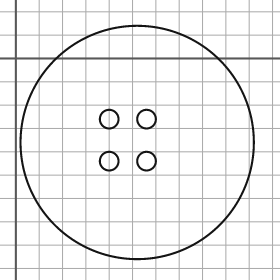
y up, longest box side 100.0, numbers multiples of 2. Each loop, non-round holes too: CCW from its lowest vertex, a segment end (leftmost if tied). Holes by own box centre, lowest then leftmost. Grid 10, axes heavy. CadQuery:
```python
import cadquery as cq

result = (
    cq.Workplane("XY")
    .moveTo(52.0, -36.0)
    .circle(50.0)
    .moveTo(40.0, -44.0)
    .circle(4.0)
    .moveTo(56.0, -44.0)
    .circle(4.0)
    .moveTo(40.0, -26.0)
    .circle(4.0)
    .moveTo(56.0, -26.0)
    .circle(4.0)
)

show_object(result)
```